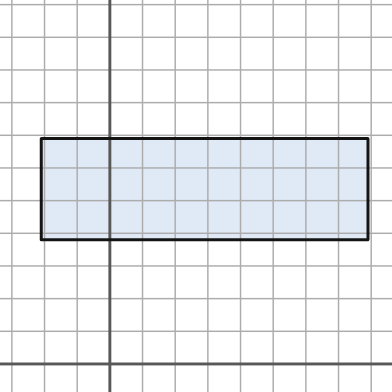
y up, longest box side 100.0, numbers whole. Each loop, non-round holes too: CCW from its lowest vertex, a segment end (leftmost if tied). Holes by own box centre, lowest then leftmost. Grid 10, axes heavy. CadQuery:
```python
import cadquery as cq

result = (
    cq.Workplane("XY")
    .moveTo(-21.0, 38.0)
    .lineTo(79.0, 38.0)
    .lineTo(79.0, 69.0)
    .lineTo(-21.0, 69.0)
    .close()
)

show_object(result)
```